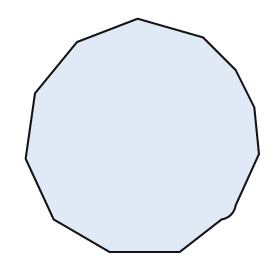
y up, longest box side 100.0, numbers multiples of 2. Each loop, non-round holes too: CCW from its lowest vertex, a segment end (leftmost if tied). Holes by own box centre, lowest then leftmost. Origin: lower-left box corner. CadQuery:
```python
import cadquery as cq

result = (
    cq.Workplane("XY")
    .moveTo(36.0, 0.0)
    .lineTo(66.0, 0.0)
    .lineTo(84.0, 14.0)
    .threePointArc((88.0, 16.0), (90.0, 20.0))
    .lineTo(100.0, 42.0)
    .lineTo(98.0, 62.0)
    .lineTo(90.0, 78.0)
    .lineTo(76.0, 92.0)
    .lineTo(48.0, 100.0)
    .lineTo(22.0, 90.0)
    .lineTo(4.0, 68.0)
    .lineTo(0.0, 40.0)
    .lineTo(12.0, 14.0)
    .close()
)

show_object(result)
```